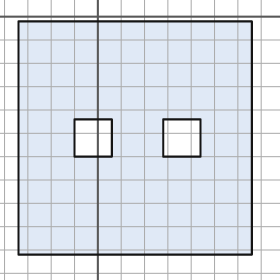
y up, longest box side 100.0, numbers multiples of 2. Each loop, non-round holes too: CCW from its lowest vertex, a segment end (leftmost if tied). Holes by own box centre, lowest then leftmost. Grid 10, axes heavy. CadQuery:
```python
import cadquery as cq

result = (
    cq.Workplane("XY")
    .moveTo(-34.0, -102.0)
    .lineTo(66.0, -102.0)
    .lineTo(66.0, -2.0)
    .lineTo(-34.0, -2.0)
    .close()
    .moveTo(-10.0, -60.0)
    .lineTo(6.0, -60.0)
    .lineTo(6.0, -44.0)
    .lineTo(-10.0, -44.0)
    .close()
    .moveTo(28.0, -60.0)
    .lineTo(44.0, -60.0)
    .lineTo(44.0, -44.0)
    .lineTo(28.0, -44.0)
    .close()
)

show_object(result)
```